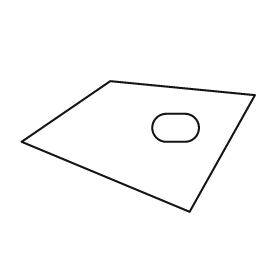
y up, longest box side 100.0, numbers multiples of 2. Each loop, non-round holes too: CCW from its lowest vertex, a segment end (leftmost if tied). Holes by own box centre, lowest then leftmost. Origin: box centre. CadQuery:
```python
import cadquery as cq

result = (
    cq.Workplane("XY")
    .moveTo(22.0, -28.0)
    .lineTo(50.0, 22.0)
    .lineTo(-12.0, 28.0)
    .lineTo(-50.0, 2.0)
    .close()
    .moveTo(12.0, 2.0)
    .lineTo(20.0, 2.0)
    .threePointArc((26.0, 8.0), (20.0, 14.0))
    .lineTo(12.0, 14.0)
    .threePointArc((6.0, 8.0), (12.0, 2.0))
    .close()
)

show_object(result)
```